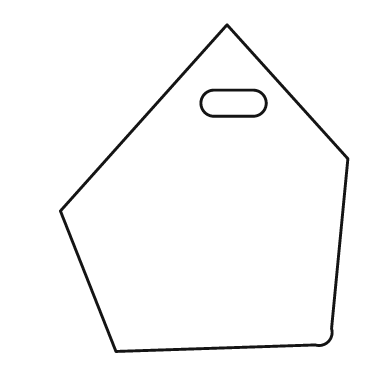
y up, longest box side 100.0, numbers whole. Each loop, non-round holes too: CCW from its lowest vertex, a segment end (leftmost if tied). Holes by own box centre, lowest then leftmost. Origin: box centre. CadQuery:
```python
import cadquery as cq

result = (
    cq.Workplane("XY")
    .moveTo(-27.0, -50.0)
    .lineTo(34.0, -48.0)
    .threePointArc((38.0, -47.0), (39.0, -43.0))
    .lineTo(44.0, 9.0)
    .lineTo(7.0, 50.0)
    .lineTo(-44.0, -7.0)
    .close()
    .moveTo(3.0, 22.0)
    .lineTo(15.0, 22.0)
    .threePointArc((19.0, 26.0), (15.0, 30.0))
    .lineTo(3.0, 30.0)
    .threePointArc((-1.0, 26.0), (3.0, 22.0))
    .close()
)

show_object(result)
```